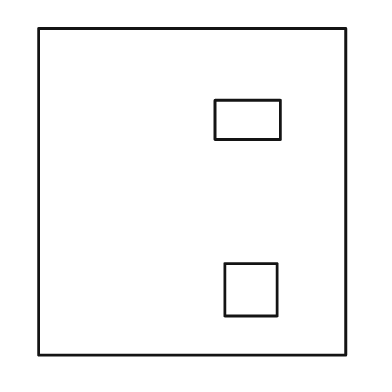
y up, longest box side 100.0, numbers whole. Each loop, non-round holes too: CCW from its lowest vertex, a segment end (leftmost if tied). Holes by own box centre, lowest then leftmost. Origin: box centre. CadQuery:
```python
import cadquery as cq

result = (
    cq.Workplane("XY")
    .moveTo(-47.0, -50.0)
    .lineTo(47.0, -50.0)
    .lineTo(47.0, 50.0)
    .lineTo(-47.0, 50.0)
    .close()
    .moveTo(10.0, -38.0)
    .lineTo(26.0, -38.0)
    .lineTo(26.0, -22.0)
    .lineTo(10.0, -22.0)
    .close()
    .moveTo(7.0, 16.0)
    .lineTo(27.0, 16.0)
    .lineTo(27.0, 28.0)
    .lineTo(7.0, 28.0)
    .close()
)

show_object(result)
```